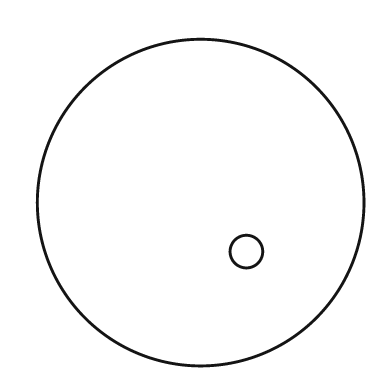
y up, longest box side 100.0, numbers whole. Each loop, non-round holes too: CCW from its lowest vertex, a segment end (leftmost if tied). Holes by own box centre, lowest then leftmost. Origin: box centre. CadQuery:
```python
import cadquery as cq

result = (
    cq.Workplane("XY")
    .moveTo(0.0, 0.0)
    .circle(50.0)
    .moveTo(14.0, -15.0)
    .circle(5.0)
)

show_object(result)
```